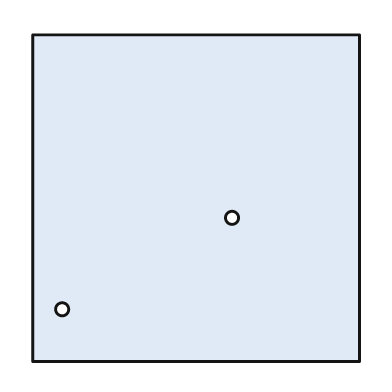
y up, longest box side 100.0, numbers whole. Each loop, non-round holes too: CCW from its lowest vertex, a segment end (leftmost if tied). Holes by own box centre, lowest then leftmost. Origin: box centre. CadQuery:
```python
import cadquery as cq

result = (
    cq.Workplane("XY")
    .moveTo(-50.0, -50.0)
    .lineTo(50.0, -50.0)
    .lineTo(50.0, 50.0)
    .lineTo(-50.0, 50.0)
    .close()
    .moveTo(-41.0, -34.0)
    .circle(2.0)
    .moveTo(11.0, -6.0)
    .circle(2.0)
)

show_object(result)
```